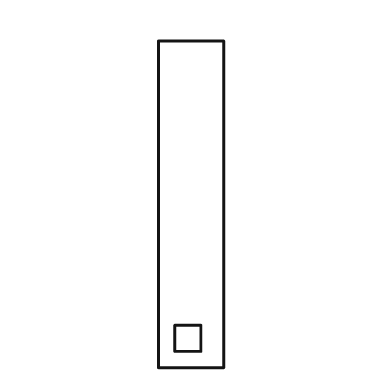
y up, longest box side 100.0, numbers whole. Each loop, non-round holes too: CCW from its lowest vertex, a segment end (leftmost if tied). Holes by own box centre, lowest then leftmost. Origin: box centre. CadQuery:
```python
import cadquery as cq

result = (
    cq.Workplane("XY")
    .moveTo(-10.0, -50.0)
    .lineTo(10.0, -50.0)
    .lineTo(10.0, 50.0)
    .lineTo(-10.0, 50.0)
    .close()
    .moveTo(-5.0, -45.0)
    .lineTo(3.0, -45.0)
    .lineTo(3.0, -37.0)
    .lineTo(-5.0, -37.0)
    .close()
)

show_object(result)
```